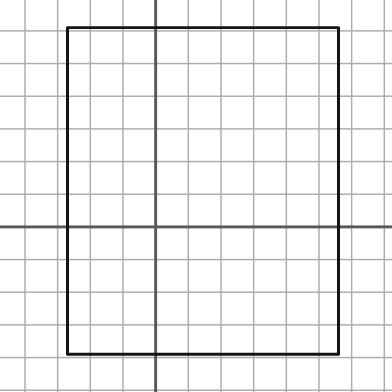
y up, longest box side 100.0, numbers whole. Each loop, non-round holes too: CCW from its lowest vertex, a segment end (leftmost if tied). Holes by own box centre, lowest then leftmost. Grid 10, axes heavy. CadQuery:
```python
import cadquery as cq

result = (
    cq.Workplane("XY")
    .moveTo(-27.0, -39.0)
    .lineTo(56.0, -39.0)
    .lineTo(56.0, 61.0)
    .lineTo(-27.0, 61.0)
    .close()
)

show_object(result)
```